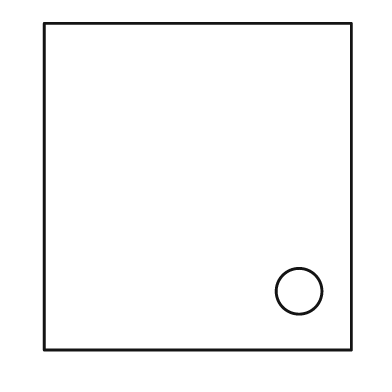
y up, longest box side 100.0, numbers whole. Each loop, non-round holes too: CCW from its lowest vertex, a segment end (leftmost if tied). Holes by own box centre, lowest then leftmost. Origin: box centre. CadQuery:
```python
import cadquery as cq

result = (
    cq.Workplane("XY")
    .moveTo(-47.0, -50.0)
    .lineTo(47.0, -50.0)
    .lineTo(47.0, 50.0)
    .lineTo(-47.0, 50.0)
    .close()
    .moveTo(31.0, -32.0)
    .circle(7.0)
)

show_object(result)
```